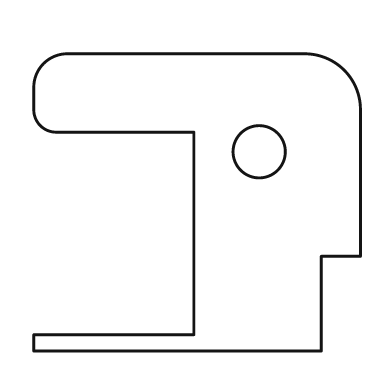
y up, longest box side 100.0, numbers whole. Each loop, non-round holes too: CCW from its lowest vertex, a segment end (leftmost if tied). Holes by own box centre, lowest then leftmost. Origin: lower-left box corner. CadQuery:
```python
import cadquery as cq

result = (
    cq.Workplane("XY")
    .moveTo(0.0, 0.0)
    .lineTo(88.0, 0.0)
    .lineTo(88.0, 29.0)
    .lineTo(100.0, 29.0)
    .lineTo(100.0, 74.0)
    .threePointArc((95.0, 86.0), (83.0, 91.0))
    .lineTo(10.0, 91.0)
    .threePointArc((3.0, 88.0), (0.0, 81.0))
    .lineTo(0.0, 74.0)
    .threePointArc((2.0, 69.0), (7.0, 67.0))
    .lineTo(49.0, 67.0)
    .lineTo(49.0, 5.0)
    .lineTo(0.0, 5.0)
    .close()
    .moveTo(69.0, 61.0)
    .circle(8.0)
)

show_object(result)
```